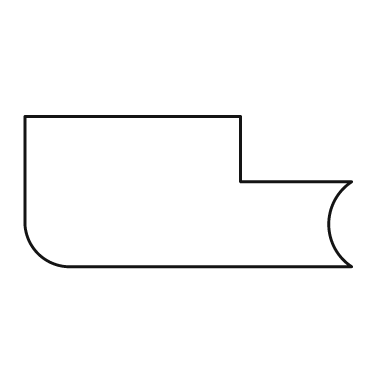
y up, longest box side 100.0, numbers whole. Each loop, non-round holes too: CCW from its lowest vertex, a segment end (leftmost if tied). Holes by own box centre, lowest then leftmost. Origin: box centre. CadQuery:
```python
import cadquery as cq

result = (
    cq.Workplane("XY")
    .moveTo(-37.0, -23.0)
    .lineTo(50.0, -23.0)
    .threePointArc((43.0, -10.0), (50.0, 3.0))
    .lineTo(16.0, 3.0)
    .lineTo(16.0, 23.0)
    .lineTo(-50.0, 23.0)
    .lineTo(-50.0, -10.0)
    .threePointArc((-46.0, -19.0), (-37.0, -23.0))
    .close()
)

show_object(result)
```